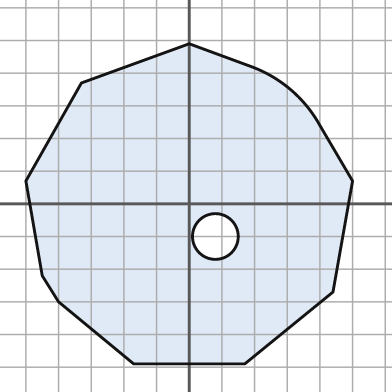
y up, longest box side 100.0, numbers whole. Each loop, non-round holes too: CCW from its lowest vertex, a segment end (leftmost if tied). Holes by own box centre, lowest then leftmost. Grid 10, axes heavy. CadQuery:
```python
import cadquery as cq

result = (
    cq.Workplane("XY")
    .moveTo(-17.0, -49.0)
    .lineTo(17.0, -49.0)
    .lineTo(44.0, -27.0)
    .lineTo(50.0, 7.0)
    .lineTo(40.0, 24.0)
    .threePointArc((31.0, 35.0), (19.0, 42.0))
    .lineTo(0.0, 49.0)
    .lineTo(-33.0, 37.0)
    .lineTo(-50.0, 7.0)
    .lineTo(-45.0, -22.0)
    .lineTo(-40.0, -30.0)
    .close()
    .moveTo(8.0, -10.0)
    .circle(7.0)
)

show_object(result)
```